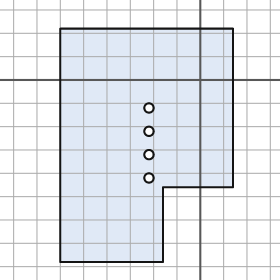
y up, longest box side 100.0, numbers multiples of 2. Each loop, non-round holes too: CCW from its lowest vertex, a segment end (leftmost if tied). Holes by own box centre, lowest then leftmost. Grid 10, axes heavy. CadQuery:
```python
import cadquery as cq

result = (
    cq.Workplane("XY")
    .moveTo(-60.0, -78.0)
    .lineTo(-16.0, -78.0)
    .lineTo(-16.0, -46.0)
    .lineTo(14.0, -46.0)
    .lineTo(14.0, 22.0)
    .lineTo(-60.0, 22.0)
    .close()
    .moveTo(-22.0, -42.0)
    .circle(2.0)
    .moveTo(-22.0, -32.0)
    .circle(2.0)
    .moveTo(-22.0, -22.0)
    .circle(2.0)
    .moveTo(-22.0, -12.0)
    .circle(2.0)
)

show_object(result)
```